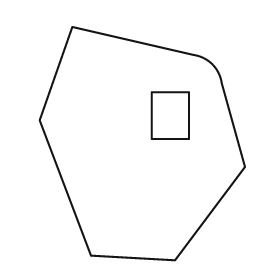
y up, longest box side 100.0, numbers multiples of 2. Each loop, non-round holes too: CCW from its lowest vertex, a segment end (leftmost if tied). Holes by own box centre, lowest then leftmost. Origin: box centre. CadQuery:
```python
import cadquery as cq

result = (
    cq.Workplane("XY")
    .moveTo(14.0, -50.0)
    .lineTo(44.0, -10.0)
    .lineTo(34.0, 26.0)
    .threePointArc((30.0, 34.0), (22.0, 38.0))
    .lineTo(-30.0, 50.0)
    .lineTo(-44.0, 10.0)
    .lineTo(-22.0, -48.0)
    .close()
    .moveTo(4.0, 2.0)
    .lineTo(20.0, 2.0)
    .lineTo(20.0, 22.0)
    .lineTo(4.0, 22.0)
    .close()
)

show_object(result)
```